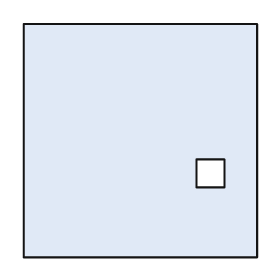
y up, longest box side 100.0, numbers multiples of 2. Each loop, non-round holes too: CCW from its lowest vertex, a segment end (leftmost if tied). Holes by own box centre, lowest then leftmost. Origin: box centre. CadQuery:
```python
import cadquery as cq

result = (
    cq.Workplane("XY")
    .moveTo(-50.0, -50.0)
    .lineTo(50.0, -50.0)
    .lineTo(50.0, 50.0)
    .lineTo(-50.0, 50.0)
    .close()
    .moveTo(24.0, -20.0)
    .lineTo(36.0, -20.0)
    .lineTo(36.0, -8.0)
    .lineTo(24.0, -8.0)
    .close()
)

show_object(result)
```